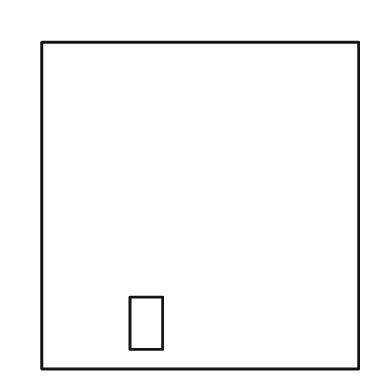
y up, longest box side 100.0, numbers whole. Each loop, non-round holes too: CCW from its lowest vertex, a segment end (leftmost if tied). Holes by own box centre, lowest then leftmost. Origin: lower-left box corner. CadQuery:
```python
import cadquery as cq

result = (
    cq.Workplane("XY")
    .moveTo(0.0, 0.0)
    .lineTo(97.0, 0.0)
    .lineTo(97.0, 100.0)
    .lineTo(0.0, 100.0)
    .close()
    .moveTo(27.0, 6.0)
    .lineTo(37.0, 6.0)
    .lineTo(37.0, 22.0)
    .lineTo(27.0, 22.0)
    .close()
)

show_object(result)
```